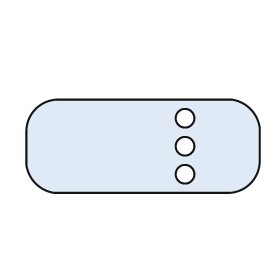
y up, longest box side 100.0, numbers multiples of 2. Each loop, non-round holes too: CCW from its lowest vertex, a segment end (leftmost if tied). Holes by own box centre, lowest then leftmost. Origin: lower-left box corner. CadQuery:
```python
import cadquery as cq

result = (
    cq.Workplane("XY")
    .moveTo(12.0, 0.0)
    .lineTo(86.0, 0.0)
    .threePointArc((96.0, 4.0), (100.0, 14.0))
    .lineTo(100.0, 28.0)
    .threePointArc((96.0, 36.0), (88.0, 40.0))
    .lineTo(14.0, 40.0)
    .threePointArc((4.0, 36.0), (0.0, 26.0))
    .lineTo(0.0, 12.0)
    .threePointArc((4.0, 4.0), (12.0, 0.0))
    .close()
    .moveTo(68.0, 8.0)
    .circle(4.0)
    .moveTo(68.0, 20.0)
    .circle(4.0)
    .moveTo(68.0, 32.0)
    .circle(4.0)
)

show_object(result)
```